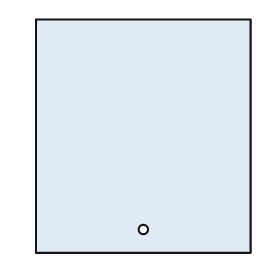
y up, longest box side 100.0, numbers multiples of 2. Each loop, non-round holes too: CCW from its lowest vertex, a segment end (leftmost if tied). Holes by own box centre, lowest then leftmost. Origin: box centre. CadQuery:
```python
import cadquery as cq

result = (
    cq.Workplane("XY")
    .moveTo(-46.0, -50.0)
    .lineTo(46.0, -50.0)
    .lineTo(46.0, 50.0)
    .lineTo(-46.0, 50.0)
    .close()
    .moveTo(0.0, -40.0)
    .circle(2.0)
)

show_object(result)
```